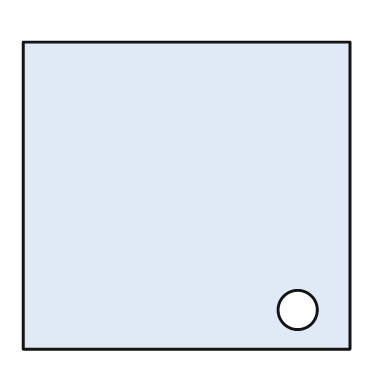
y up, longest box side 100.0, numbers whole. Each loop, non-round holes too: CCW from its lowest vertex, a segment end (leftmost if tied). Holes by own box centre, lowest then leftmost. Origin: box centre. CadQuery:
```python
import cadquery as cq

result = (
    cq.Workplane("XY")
    .moveTo(-50.0, -47.0)
    .lineTo(50.0, -47.0)
    .lineTo(50.0, 47.0)
    .lineTo(-50.0, 47.0)
    .close()
    .moveTo(34.0, -35.0)
    .circle(6.0)
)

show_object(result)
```